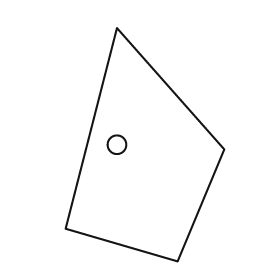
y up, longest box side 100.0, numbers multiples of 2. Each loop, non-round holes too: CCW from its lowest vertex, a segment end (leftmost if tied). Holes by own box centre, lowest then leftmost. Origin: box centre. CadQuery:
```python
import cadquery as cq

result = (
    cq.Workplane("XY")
    .moveTo(14.0, -50.0)
    .lineTo(34.0, -2.0)
    .lineTo(-12.0, 50.0)
    .lineTo(-34.0, -36.0)
    .close()
    .moveTo(-12.0, 0.0)
    .circle(4.0)
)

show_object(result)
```